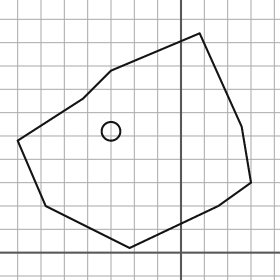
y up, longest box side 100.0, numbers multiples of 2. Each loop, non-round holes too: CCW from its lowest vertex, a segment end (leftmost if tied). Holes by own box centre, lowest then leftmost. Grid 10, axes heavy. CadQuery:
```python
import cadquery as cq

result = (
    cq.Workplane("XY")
    .moveTo(-22.0, 2.0)
    .lineTo(16.0, 20.0)
    .lineTo(30.0, 30.0)
    .lineTo(26.0, 54.0)
    .lineTo(8.0, 94.0)
    .lineTo(-30.0, 78.0)
    .lineTo(-42.0, 66.0)
    .lineTo(-70.0, 48.0)
    .lineTo(-58.0, 20.0)
    .close()
    .moveTo(-30.0, 52.0)
    .circle(4.0)
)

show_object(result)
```